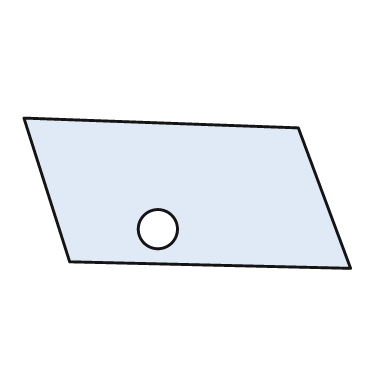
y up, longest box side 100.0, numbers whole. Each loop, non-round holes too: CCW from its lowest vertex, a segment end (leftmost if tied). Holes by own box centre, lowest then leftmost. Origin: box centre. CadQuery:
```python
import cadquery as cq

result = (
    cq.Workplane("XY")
    .moveTo(50.0, -23.0)
    .lineTo(34.0, 20.0)
    .lineTo(-50.0, 23.0)
    .lineTo(-36.0, -21.0)
    .close()
    .moveTo(-9.0, -11.0)
    .circle(6.0)
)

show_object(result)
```